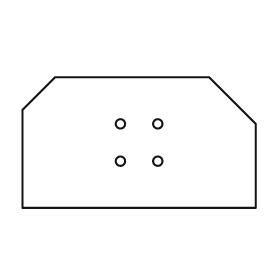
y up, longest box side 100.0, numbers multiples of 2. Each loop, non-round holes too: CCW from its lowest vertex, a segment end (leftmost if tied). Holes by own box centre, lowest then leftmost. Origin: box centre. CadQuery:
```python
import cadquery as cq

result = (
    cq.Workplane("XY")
    .moveTo(-50.0, -28.0)
    .lineTo(50.0, -28.0)
    .lineTo(50.0, 8.0)
    .lineTo(30.0, 28.0)
    .lineTo(-36.0, 28.0)
    .lineTo(-50.0, 14.0)
    .close()
    .moveTo(-8.0, -8.0)
    .circle(2.0)
    .moveTo(8.0, -8.0)
    .circle(2.0)
    .moveTo(-8.0, 8.0)
    .circle(2.0)
    .moveTo(8.0, 8.0)
    .circle(2.0)
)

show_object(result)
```